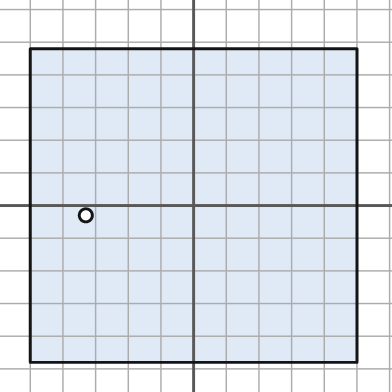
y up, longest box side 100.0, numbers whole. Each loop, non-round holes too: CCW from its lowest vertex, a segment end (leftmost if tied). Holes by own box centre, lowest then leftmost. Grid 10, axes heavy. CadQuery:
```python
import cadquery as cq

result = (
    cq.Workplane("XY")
    .moveTo(-50.0, -48.0)
    .lineTo(50.0, -48.0)
    .lineTo(50.0, 48.0)
    .lineTo(-50.0, 48.0)
    .close()
    .moveTo(-33.0, -3.0)
    .circle(2.0)
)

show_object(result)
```